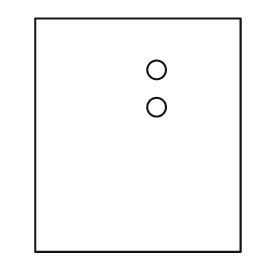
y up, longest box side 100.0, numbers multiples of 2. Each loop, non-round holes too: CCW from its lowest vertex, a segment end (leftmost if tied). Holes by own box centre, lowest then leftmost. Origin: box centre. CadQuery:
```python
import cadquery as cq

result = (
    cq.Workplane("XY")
    .moveTo(-44.0, -50.0)
    .lineTo(44.0, -50.0)
    .lineTo(44.0, 50.0)
    .lineTo(-44.0, 50.0)
    .close()
    .moveTo(8.0, 12.0)
    .circle(4.0)
    .moveTo(8.0, 28.0)
    .circle(4.0)
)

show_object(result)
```